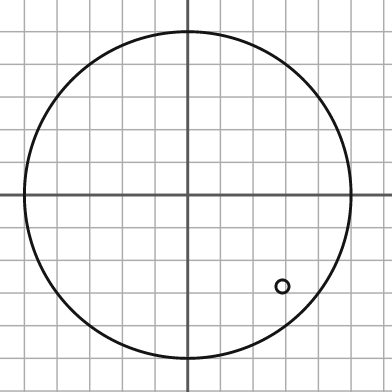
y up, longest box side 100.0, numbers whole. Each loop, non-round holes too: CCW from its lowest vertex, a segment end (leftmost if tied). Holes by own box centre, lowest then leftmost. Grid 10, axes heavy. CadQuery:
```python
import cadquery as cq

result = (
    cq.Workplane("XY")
    .moveTo(0.0, 0.0)
    .circle(50.0)
    .moveTo(29.0, -28.0)
    .circle(2.0)
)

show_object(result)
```